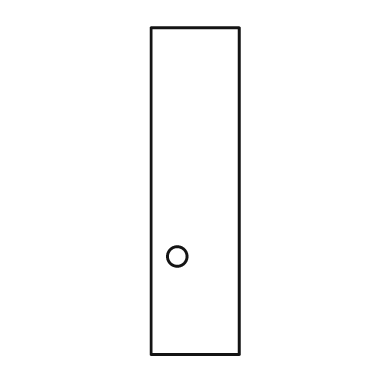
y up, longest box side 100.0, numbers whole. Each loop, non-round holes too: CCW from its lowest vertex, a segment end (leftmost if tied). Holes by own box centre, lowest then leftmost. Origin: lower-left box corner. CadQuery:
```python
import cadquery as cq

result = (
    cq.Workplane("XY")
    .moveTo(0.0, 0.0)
    .lineTo(27.0, 0.0)
    .lineTo(27.0, 100.0)
    .lineTo(0.0, 100.0)
    .close()
    .moveTo(8.0, 30.0)
    .circle(3.0)
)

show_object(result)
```